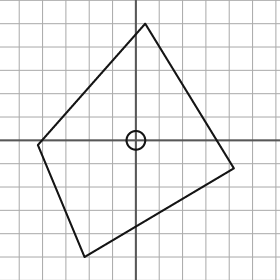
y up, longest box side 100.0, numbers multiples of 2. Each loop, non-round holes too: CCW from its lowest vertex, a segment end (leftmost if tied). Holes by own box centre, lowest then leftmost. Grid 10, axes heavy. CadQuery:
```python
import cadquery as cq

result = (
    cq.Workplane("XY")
    .moveTo(-22.0, -50.0)
    .lineTo(42.0, -12.0)
    .lineTo(4.0, 50.0)
    .lineTo(-42.0, -2.0)
    .close()
    .moveTo(0.0, 0.0)
    .circle(4.0)
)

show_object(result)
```